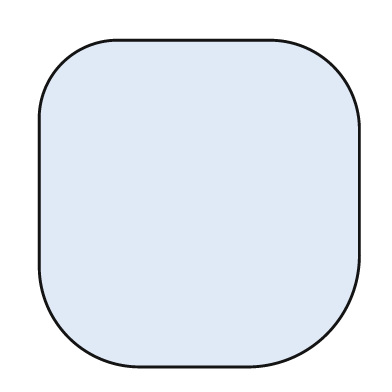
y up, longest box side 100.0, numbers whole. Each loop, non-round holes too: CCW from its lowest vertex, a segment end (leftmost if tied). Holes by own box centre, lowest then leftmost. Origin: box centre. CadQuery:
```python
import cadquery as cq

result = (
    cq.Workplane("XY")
    .moveTo(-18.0, -50.0)
    .lineTo(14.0, -50.0)
    .threePointArc((39.0, -40.0), (49.0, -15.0))
    .lineTo(49.0, 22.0)
    .threePointArc((41.0, 42.0), (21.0, 50.0))
    .lineTo(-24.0, 50.0)
    .threePointArc((-42.0, 43.0), (-49.0, 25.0))
    .lineTo(-49.0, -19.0)
    .threePointArc((-40.0, -41.0), (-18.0, -50.0))
    .close()
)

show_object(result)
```